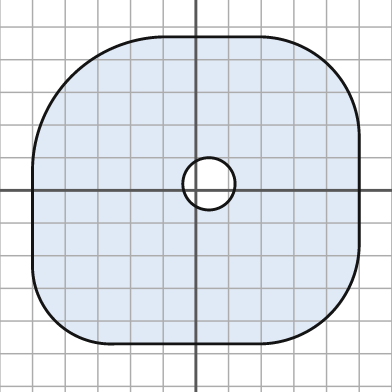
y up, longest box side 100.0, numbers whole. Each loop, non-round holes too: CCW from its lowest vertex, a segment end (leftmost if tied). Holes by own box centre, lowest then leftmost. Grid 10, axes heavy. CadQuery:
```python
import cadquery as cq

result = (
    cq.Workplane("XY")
    .moveTo(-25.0, -47.0)
    .lineTo(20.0, -47.0)
    .threePointArc((41.0, -38.0), (50.0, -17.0))
    .lineTo(50.0, 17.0)
    .threePointArc((41.0, 38.0), (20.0, 47.0))
    .lineTo(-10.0, 47.0)
    .threePointArc((-38.0, 35.0), (-50.0, 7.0))
    .lineTo(-50.0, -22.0)
    .threePointArc((-43.0, -40.0), (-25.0, -47.0))
    .close()
    .moveTo(4.0, 2.0)
    .circle(8.0)
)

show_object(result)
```